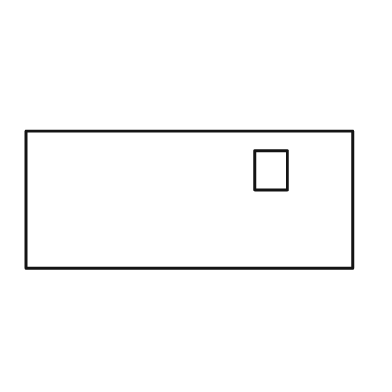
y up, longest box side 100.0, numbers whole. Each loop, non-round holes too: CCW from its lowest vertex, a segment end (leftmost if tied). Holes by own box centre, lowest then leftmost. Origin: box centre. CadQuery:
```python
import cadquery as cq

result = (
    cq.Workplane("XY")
    .moveTo(-50.0, -21.0)
    .lineTo(50.0, -21.0)
    .lineTo(50.0, 21.0)
    .lineTo(-50.0, 21.0)
    .close()
    .moveTo(20.0, 3.0)
    .lineTo(30.0, 3.0)
    .lineTo(30.0, 15.0)
    .lineTo(20.0, 15.0)
    .close()
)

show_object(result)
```